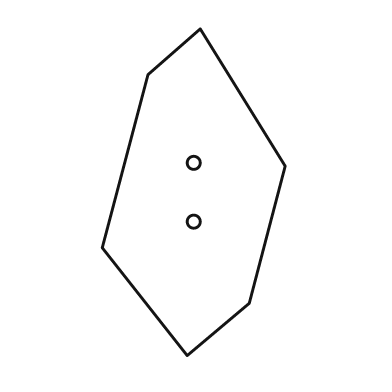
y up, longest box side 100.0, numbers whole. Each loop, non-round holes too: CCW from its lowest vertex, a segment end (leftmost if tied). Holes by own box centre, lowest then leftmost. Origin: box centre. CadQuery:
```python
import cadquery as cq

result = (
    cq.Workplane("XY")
    .moveTo(-2.0, -50.0)
    .lineTo(17.0, -34.0)
    .lineTo(28.0, 8.0)
    .lineTo(2.0, 50.0)
    .lineTo(-14.0, 36.0)
    .lineTo(-28.0, -17.0)
    .close()
    .moveTo(0.0, -9.0)
    .circle(2.0)
    .moveTo(0.0, 9.0)
    .circle(2.0)
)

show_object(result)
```